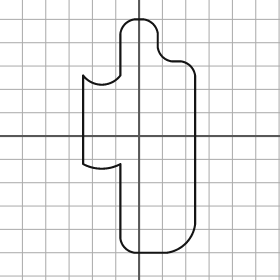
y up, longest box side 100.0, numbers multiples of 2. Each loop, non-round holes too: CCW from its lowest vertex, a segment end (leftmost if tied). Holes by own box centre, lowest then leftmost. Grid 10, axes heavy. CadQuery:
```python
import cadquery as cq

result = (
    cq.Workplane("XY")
    .moveTo(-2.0, -50.0)
    .lineTo(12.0, -50.0)
    .threePointArc((20.0, -46.0), (24.0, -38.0))
    .lineTo(24.0, 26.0)
    .threePointArc((22.0, 30.0), (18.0, 32.0))
    .lineTo(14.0, 32.0)
    .threePointArc((10.0, 34.0), (8.0, 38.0))
    .lineTo(8.0, 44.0)
    .threePointArc((6.0, 48.0), (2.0, 50.0))
    .lineTo(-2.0, 50.0)
    .threePointArc((-6.0, 48.0), (-8.0, 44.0))
    .lineTo(-8.0, 26.0)
    .threePointArc((-16.0, 22.0), (-24.0, 26.0))
    .lineTo(-24.0, -12.0)
    .threePointArc((-16.0, -14.0), (-8.0, -12.0))
    .lineTo(-8.0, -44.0)
    .threePointArc((-6.0, -48.0), (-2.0, -50.0))
    .close()
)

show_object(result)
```